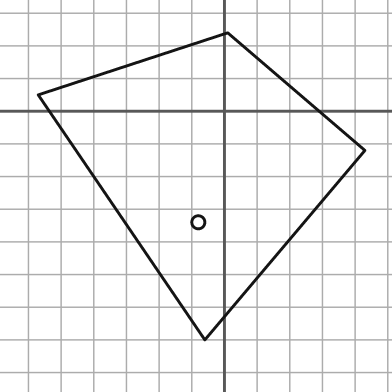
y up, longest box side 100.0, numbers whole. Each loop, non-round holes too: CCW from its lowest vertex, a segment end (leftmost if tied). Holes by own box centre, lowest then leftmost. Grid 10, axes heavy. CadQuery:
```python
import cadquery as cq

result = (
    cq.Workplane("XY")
    .moveTo(-6.0, -70.0)
    .lineTo(43.0, -12.0)
    .lineTo(1.0, 24.0)
    .lineTo(-57.0, 5.0)
    .close()
    .moveTo(-8.0, -34.0)
    .circle(2.0)
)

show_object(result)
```